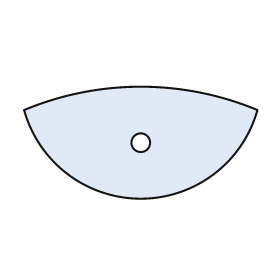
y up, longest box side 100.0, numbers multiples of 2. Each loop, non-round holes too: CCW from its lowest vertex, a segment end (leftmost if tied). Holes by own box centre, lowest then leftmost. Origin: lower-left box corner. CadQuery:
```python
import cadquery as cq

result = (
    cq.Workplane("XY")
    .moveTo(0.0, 38.0)
    .threePointArc((50.0, 0.0), (100.0, 38.0))
    .threePointArc((50.0, 48.0), (0.0, 38.0))
    .close()
    .moveTo(50.0, 24.0)
    .circle(4.0)
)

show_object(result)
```